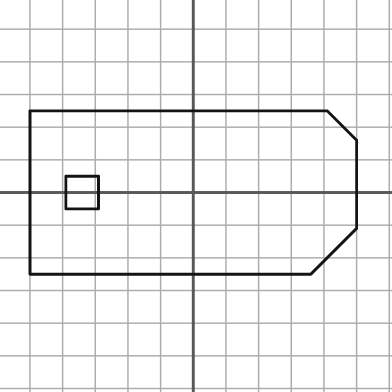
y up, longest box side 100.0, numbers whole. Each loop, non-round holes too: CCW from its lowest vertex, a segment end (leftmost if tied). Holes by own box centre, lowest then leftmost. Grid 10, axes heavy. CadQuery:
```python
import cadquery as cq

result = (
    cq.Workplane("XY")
    .moveTo(-50.0, -25.0)
    .lineTo(36.0, -25.0)
    .lineTo(50.0, -11.0)
    .lineTo(50.0, 16.0)
    .lineTo(41.0, 25.0)
    .lineTo(-50.0, 25.0)
    .close()
    .moveTo(-39.0, -5.0)
    .lineTo(-29.0, -5.0)
    .lineTo(-29.0, 5.0)
    .lineTo(-39.0, 5.0)
    .close()
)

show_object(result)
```